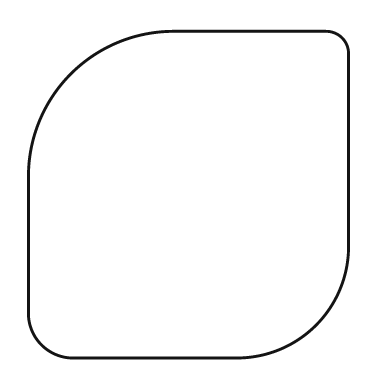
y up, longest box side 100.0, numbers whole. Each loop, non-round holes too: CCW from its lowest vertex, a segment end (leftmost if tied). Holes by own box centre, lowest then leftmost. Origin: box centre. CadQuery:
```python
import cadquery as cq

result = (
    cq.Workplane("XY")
    .moveTo(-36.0, -50.0)
    .lineTo(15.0, -50.0)
    .threePointArc((39.0, -40.0), (49.0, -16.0))
    .lineTo(49.0, 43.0)
    .threePointArc((47.0, 48.0), (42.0, 50.0))
    .lineTo(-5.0, 50.0)
    .threePointArc((-36.0, 37.0), (-49.0, 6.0))
    .lineTo(-49.0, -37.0)
    .threePointArc((-45.0, -46.0), (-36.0, -50.0))
    .close()
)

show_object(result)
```